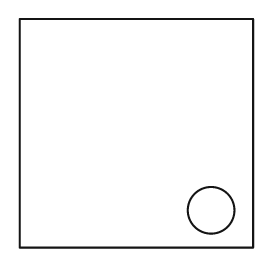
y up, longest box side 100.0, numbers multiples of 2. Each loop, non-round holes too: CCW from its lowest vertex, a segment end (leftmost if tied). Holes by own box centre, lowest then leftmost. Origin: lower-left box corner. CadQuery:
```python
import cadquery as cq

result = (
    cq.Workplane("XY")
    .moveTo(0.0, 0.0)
    .lineTo(100.0, 0.0)
    .lineTo(100.0, 98.0)
    .lineTo(0.0, 98.0)
    .close()
    .moveTo(82.0, 16.0)
    .circle(10.0)
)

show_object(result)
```